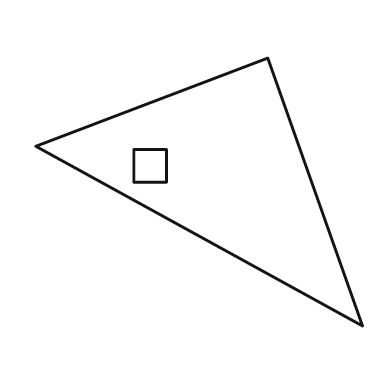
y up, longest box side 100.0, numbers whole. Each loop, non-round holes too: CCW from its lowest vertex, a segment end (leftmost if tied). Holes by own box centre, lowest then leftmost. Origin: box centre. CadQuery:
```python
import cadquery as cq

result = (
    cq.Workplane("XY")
    .moveTo(50.0, -41.0)
    .lineTo(21.0, 41.0)
    .lineTo(-50.0, 14.0)
    .close()
    .moveTo(-20.0, 3.0)
    .lineTo(-10.0, 3.0)
    .lineTo(-10.0, 13.0)
    .lineTo(-20.0, 13.0)
    .close()
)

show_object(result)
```